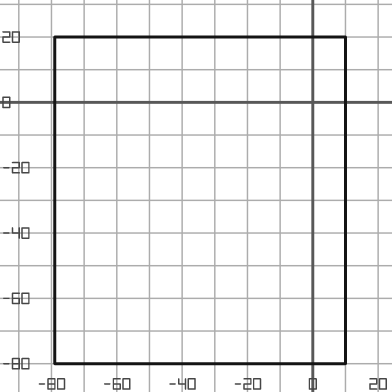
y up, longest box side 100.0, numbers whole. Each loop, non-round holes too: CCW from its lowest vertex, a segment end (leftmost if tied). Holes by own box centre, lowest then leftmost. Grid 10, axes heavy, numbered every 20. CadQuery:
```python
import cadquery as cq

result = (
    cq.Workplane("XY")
    .moveTo(-79.0, -80.0)
    .lineTo(10.0, -80.0)
    .lineTo(10.0, 20.0)
    .lineTo(-79.0, 20.0)
    .close()
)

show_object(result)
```